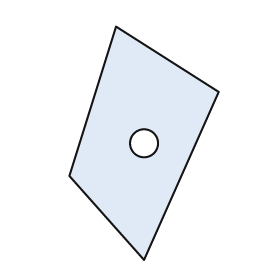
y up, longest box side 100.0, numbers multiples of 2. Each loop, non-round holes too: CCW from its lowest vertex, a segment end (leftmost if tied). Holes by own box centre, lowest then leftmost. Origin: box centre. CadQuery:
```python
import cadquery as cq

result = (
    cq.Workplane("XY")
    .moveTo(0.0, -50.0)
    .lineTo(32.0, 22.0)
    .lineTo(-12.0, 50.0)
    .lineTo(-32.0, -14.0)
    .close()
    .moveTo(0.0, 0.0)
    .circle(6.0)
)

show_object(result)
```